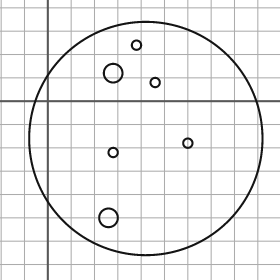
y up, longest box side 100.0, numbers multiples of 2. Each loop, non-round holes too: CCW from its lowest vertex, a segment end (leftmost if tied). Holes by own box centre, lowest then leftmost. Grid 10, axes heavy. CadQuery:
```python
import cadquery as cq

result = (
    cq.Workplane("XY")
    .moveTo(42.0, -16.0)
    .circle(50.0)
    .moveTo(26.0, -50.0)
    .circle(4.0)
    .moveTo(28.0, -22.0)
    .circle(2.0)
    .moveTo(60.0, -18.0)
    .circle(2.0)
    .moveTo(46.0, 8.0)
    .circle(2.0)
    .moveTo(28.0, 12.0)
    .circle(4.0)
    .moveTo(38.0, 24.0)
    .circle(2.0)
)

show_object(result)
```